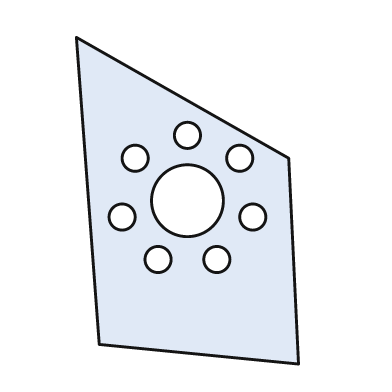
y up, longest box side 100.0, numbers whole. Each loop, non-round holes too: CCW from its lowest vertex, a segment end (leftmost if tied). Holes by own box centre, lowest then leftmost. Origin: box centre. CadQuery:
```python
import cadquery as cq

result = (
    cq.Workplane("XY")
    .moveTo(34.0, -50.0)
    .lineTo(31.0, 13.0)
    .lineTo(-34.0, 50.0)
    .lineTo(-27.0, -44.0)
    .close()
    .moveTo(-9.0, -18.0)
    .circle(4.0)
    .moveTo(9.0, -18.0)
    .circle(4.0)
    .moveTo(-20.0, -5.0)
    .circle(4.0)
    .moveTo(20.0, -5.0)
    .circle(4.0)
    .moveTo(0.0, 0.0)
    .circle(11.0)
    .moveTo(-16.0, 13.0)
    .circle(4.0)
    .moveTo(16.0, 13.0)
    .circle(4.0)
    .moveTo(0.0, 20.0)
    .circle(4.0)
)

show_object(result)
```